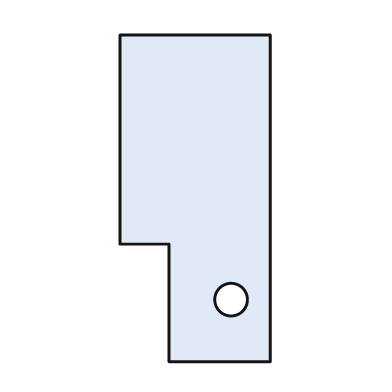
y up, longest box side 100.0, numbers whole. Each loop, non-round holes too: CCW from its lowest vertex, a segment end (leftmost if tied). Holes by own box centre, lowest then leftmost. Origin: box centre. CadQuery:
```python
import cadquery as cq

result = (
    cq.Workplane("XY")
    .moveTo(-8.0, -50.0)
    .lineTo(23.0, -50.0)
    .lineTo(23.0, 50.0)
    .lineTo(-23.0, 50.0)
    .lineTo(-23.0, -14.0)
    .lineTo(-8.0, -14.0)
    .close()
    .moveTo(11.0, -31.0)
    .circle(5.0)
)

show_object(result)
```